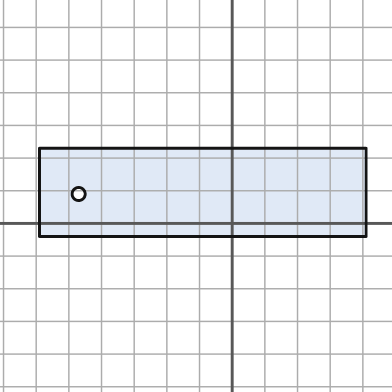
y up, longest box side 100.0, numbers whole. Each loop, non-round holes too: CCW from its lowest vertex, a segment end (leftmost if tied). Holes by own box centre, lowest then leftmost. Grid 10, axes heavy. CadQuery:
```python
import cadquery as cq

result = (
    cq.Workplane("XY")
    .moveTo(-59.0, -4.0)
    .lineTo(41.0, -4.0)
    .lineTo(41.0, 23.0)
    .lineTo(-59.0, 23.0)
    .close()
    .moveTo(-47.0, 9.0)
    .circle(2.0)
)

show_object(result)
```